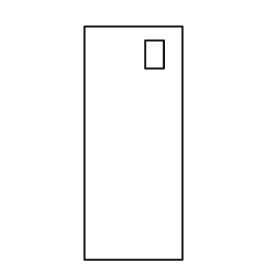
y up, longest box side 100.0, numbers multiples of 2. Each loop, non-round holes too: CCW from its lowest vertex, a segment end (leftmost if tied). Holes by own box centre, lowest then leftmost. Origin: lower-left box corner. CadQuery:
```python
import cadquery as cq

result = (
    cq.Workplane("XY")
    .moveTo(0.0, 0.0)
    .lineTo(42.0, 0.0)
    .lineTo(42.0, 100.0)
    .lineTo(0.0, 100.0)
    .close()
    .moveTo(26.0, 82.0)
    .lineTo(34.0, 82.0)
    .lineTo(34.0, 94.0)
    .lineTo(26.0, 94.0)
    .close()
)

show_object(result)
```